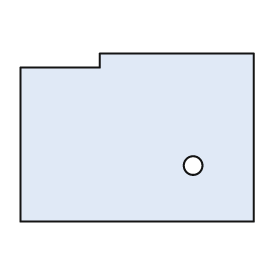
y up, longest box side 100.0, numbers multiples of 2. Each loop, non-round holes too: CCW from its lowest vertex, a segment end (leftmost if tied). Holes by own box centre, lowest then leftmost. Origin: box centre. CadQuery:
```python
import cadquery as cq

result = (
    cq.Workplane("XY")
    .moveTo(-50.0, -36.0)
    .lineTo(50.0, -36.0)
    .lineTo(50.0, 36.0)
    .lineTo(-16.0, 36.0)
    .lineTo(-16.0, 30.0)
    .lineTo(-50.0, 30.0)
    .close()
    .moveTo(24.0, -12.0)
    .circle(4.0)
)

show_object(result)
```